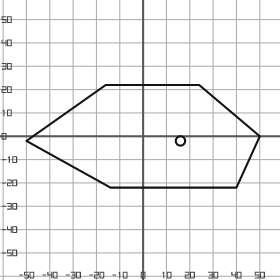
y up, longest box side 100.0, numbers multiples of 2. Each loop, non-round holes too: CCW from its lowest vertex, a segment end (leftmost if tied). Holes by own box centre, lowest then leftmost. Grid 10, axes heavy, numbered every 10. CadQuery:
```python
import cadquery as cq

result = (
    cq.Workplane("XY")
    .moveTo(-14.0, -22.0)
    .lineTo(40.0, -22.0)
    .lineTo(50.0, 0.0)
    .lineTo(24.0, 22.0)
    .lineTo(-16.0, 22.0)
    .lineTo(-50.0, -2.0)
    .close()
    .moveTo(16.0, -2.0)
    .circle(2.0)
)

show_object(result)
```